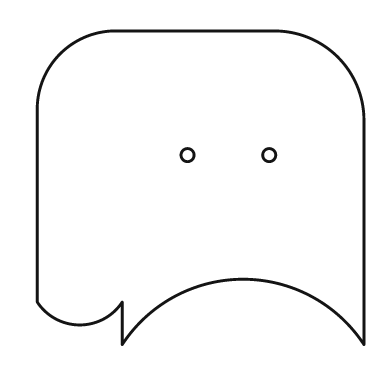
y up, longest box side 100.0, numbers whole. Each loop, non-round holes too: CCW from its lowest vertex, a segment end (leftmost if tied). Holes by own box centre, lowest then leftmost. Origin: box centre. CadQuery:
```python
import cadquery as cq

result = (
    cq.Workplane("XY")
    .moveTo(-24.0, -48.0)
    .threePointArc((13.0, -28.0), (50.0, -48.0))
    .lineTo(50.0, 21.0)
    .threePointArc((42.0, 40.0), (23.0, 48.0))
    .lineTo(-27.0, 48.0)
    .threePointArc((-43.0, 41.0), (-50.0, 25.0))
    .lineTo(-50.0, -35.0)
    .threePointArc((-37.0, -42.0), (-24.0, -35.0))
    .close()
    .moveTo(-4.0, 10.0)
    .circle(2.0)
    .moveTo(21.0, 10.0)
    .circle(2.0)
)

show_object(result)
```